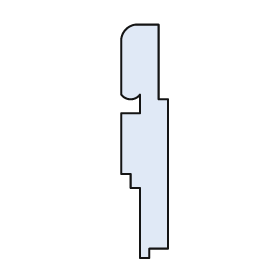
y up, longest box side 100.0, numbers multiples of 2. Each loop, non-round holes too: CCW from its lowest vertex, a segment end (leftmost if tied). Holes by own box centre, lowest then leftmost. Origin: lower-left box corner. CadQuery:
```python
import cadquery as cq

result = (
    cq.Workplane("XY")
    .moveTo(8.0, 0.0)
    .lineTo(12.0, 0.0)
    .lineTo(12.0, 4.0)
    .lineTo(20.0, 4.0)
    .lineTo(20.0, 68.0)
    .lineTo(16.0, 68.0)
    .lineTo(16.0, 100.0)
    .lineTo(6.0, 100.0)
    .threePointArc((2.0, 98.0), (0.0, 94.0))
    .lineTo(0.0, 70.0)
    .threePointArc((4.0, 68.0), (8.0, 70.0))
    .lineTo(8.0, 62.0)
    .lineTo(0.0, 62.0)
    .lineTo(0.0, 36.0)
    .lineTo(4.0, 36.0)
    .lineTo(4.0, 30.0)
    .lineTo(8.0, 30.0)
    .close()
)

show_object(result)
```